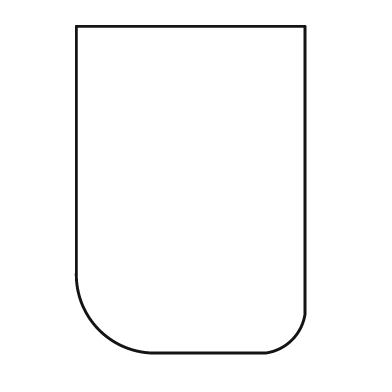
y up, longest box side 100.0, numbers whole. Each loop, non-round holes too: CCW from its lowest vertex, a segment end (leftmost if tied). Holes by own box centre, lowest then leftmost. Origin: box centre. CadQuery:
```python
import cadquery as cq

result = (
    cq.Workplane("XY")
    .moveTo(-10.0, -50.0)
    .lineTo(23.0, -50.0)
    .threePointArc((31.0, -46.0), (35.0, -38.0))
    .lineTo(35.0, 50.0)
    .lineTo(-35.0, 50.0)
    .lineTo(-35.0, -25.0)
    .threePointArc((-28.0, -43.0), (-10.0, -50.0))
    .close()
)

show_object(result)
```